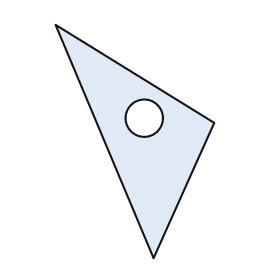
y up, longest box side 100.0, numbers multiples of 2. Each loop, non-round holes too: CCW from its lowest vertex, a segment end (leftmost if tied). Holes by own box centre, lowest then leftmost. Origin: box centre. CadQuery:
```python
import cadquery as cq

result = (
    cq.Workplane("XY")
    .moveTo(8.0, -50.0)
    .lineTo(34.0, 8.0)
    .lineTo(-34.0, 50.0)
    .close()
    .moveTo(4.0, 10.0)
    .circle(8.0)
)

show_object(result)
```